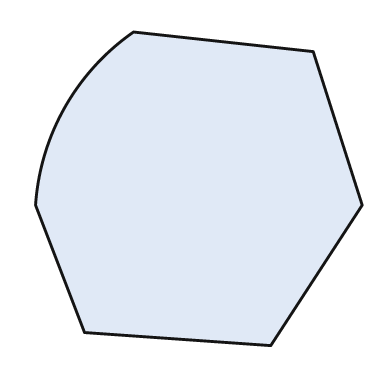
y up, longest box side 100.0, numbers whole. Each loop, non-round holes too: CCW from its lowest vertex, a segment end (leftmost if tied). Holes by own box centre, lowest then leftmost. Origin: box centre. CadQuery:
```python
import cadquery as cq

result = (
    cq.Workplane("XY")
    .moveTo(22.0, -48.0)
    .lineTo(50.0, -5.0)
    .lineTo(35.0, 42.0)
    .lineTo(-20.0, 48.0)
    .threePointArc((-41.0, 25.0), (-50.0, -5.0))
    .lineTo(-35.0, -44.0)
    .close()
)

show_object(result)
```